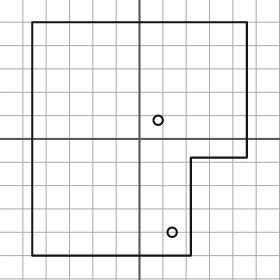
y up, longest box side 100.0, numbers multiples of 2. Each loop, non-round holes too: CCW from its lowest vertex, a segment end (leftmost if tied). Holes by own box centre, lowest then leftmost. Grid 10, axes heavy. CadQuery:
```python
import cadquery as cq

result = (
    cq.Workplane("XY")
    .moveTo(-46.0, -50.0)
    .lineTo(22.0, -50.0)
    .lineTo(22.0, -8.0)
    .lineTo(46.0, -8.0)
    .lineTo(46.0, 50.0)
    .lineTo(-46.0, 50.0)
    .close()
    .moveTo(14.0, -40.0)
    .circle(2.0)
    .moveTo(8.0, 8.0)
    .circle(2.0)
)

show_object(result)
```